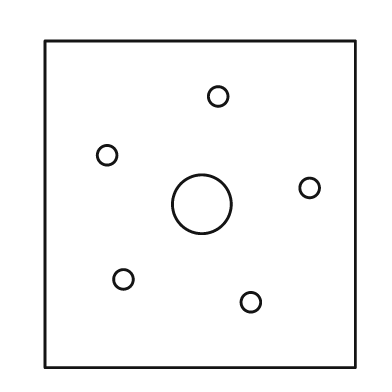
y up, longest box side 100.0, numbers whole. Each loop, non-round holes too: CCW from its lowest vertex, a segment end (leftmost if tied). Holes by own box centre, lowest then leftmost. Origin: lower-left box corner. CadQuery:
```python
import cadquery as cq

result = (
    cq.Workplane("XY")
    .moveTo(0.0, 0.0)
    .lineTo(95.0, 0.0)
    .lineTo(95.0, 100.0)
    .lineTo(0.0, 100.0)
    .close()
    .moveTo(63.0, 20.0)
    .circle(3.0)
    .moveTo(24.0, 27.0)
    .circle(3.0)
    .moveTo(48.0, 50.0)
    .circle(9.0)
    .moveTo(81.0, 55.0)
    .circle(3.0)
    .moveTo(19.0, 65.0)
    .circle(3.0)
    .moveTo(53.0, 83.0)
    .circle(3.0)
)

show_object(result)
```